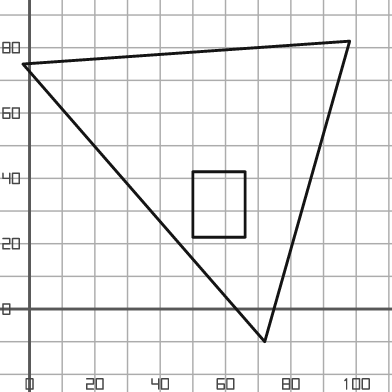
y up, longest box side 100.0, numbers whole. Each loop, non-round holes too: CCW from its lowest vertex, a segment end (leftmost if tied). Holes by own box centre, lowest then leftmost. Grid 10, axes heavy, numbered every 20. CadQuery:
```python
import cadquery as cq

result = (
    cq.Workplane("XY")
    .moveTo(72.0, -10.0)
    .lineTo(98.0, 82.0)
    .lineTo(-2.0, 75.0)
    .close()
    .moveTo(50.0, 22.0)
    .lineTo(66.0, 22.0)
    .lineTo(66.0, 42.0)
    .lineTo(50.0, 42.0)
    .close()
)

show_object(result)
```